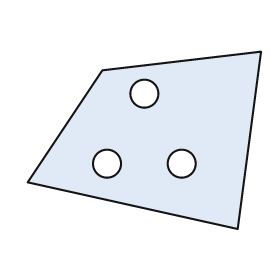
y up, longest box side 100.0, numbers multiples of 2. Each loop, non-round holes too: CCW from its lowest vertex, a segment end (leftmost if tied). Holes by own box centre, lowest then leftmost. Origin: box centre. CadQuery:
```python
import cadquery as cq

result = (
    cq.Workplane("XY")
    .moveTo(40.0, -38.0)
    .lineTo(50.0, 38.0)
    .lineTo(-18.0, 30.0)
    .lineTo(-50.0, -18.0)
    .close()
    .moveTo(-16.0, -10.0)
    .circle(6.0)
    .moveTo(16.0, -10.0)
    .circle(6.0)
    .moveTo(0.0, 20.0)
    .circle(6.0)
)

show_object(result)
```